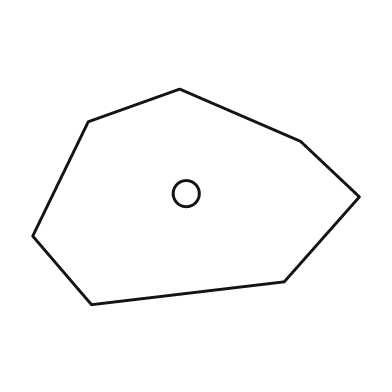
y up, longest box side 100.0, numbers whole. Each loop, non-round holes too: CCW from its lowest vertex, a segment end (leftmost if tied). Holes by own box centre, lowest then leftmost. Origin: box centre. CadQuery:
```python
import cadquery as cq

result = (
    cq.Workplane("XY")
    .moveTo(-32.0, -33.0)
    .lineTo(27.0, -26.0)
    .lineTo(50.0, 0.0)
    .lineTo(32.0, 17.0)
    .lineTo(-5.0, 33.0)
    .lineTo(-33.0, 23.0)
    .lineTo(-50.0, -12.0)
    .close()
    .moveTo(-3.0, 1.0)
    .circle(4.0)
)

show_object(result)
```